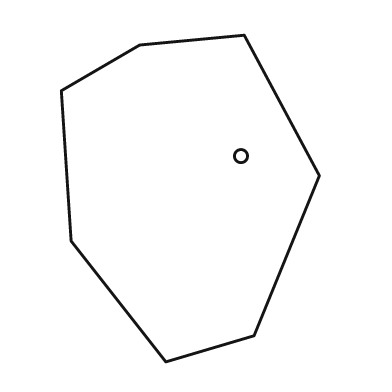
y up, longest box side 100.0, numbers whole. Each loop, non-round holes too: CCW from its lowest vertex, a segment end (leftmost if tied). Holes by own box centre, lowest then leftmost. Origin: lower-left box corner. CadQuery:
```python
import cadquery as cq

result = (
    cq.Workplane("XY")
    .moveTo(32.0, 0.0)
    .lineTo(59.0, 8.0)
    .lineTo(79.0, 57.0)
    .lineTo(56.0, 100.0)
    .lineTo(24.0, 97.0)
    .lineTo(0.0, 83.0)
    .lineTo(3.0, 37.0)
    .close()
    .moveTo(55.0, 63.0)
    .circle(2.0)
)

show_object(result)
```